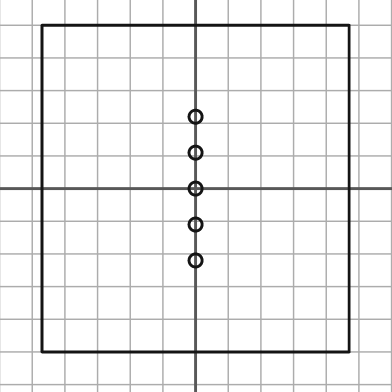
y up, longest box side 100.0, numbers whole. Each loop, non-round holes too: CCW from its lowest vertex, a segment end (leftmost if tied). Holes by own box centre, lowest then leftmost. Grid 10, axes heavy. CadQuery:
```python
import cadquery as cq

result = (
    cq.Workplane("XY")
    .moveTo(-47.0, -50.0)
    .lineTo(47.0, -50.0)
    .lineTo(47.0, 50.0)
    .lineTo(-47.0, 50.0)
    .close()
    .moveTo(0.0, -22.0)
    .circle(2.0)
    .moveTo(0.0, -11.0)
    .circle(2.0)
    .moveTo(0.0, 0.0)
    .circle(2.0)
    .moveTo(0.0, 11.0)
    .circle(2.0)
    .moveTo(0.0, 22.0)
    .circle(2.0)
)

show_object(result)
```